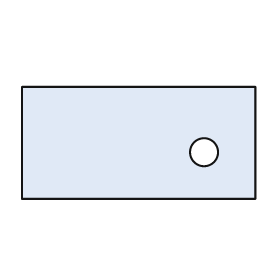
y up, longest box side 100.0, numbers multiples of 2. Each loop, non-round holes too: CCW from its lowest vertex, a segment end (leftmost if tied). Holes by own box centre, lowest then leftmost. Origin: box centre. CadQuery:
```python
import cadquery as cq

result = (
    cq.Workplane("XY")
    .moveTo(-50.0, -24.0)
    .lineTo(50.0, -24.0)
    .lineTo(50.0, 24.0)
    .lineTo(-50.0, 24.0)
    .close()
    .moveTo(28.0, -4.0)
    .circle(6.0)
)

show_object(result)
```